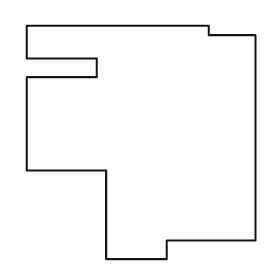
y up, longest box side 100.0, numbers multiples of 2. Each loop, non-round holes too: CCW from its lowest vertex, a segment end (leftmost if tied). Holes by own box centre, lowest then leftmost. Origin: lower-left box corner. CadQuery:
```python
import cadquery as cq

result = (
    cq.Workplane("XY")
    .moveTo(34.0, 0.0)
    .lineTo(60.0, 0.0)
    .lineTo(60.0, 8.0)
    .lineTo(98.0, 8.0)
    .lineTo(98.0, 96.0)
    .lineTo(78.0, 96.0)
    .lineTo(78.0, 100.0)
    .lineTo(0.0, 100.0)
    .lineTo(0.0, 86.0)
    .lineTo(30.0, 86.0)
    .lineTo(30.0, 78.0)
    .lineTo(0.0, 78.0)
    .lineTo(0.0, 38.0)
    .lineTo(34.0, 38.0)
    .close()
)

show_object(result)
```